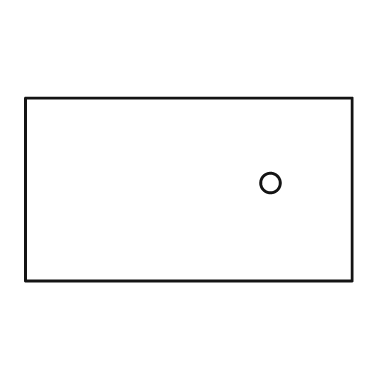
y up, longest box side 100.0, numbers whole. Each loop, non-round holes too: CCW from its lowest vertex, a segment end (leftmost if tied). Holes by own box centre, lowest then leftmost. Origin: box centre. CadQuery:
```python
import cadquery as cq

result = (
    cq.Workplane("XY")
    .moveTo(-50.0, -28.0)
    .lineTo(50.0, -28.0)
    .lineTo(50.0, 28.0)
    .lineTo(-50.0, 28.0)
    .close()
    .moveTo(25.0, 2.0)
    .circle(3.0)
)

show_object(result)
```